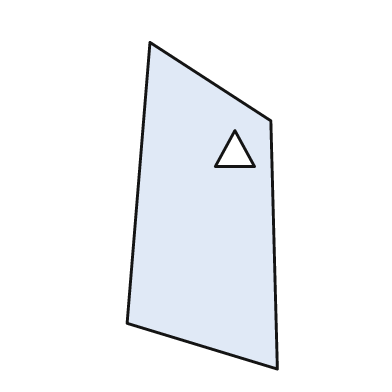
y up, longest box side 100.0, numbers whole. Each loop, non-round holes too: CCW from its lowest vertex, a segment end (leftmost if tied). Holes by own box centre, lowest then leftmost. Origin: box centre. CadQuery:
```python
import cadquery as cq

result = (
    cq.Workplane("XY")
    .moveTo(23.0, -50.0)
    .lineTo(21.0, 26.0)
    .lineTo(-16.0, 50.0)
    .lineTo(-23.0, -36.0)
    .close()
    .moveTo(4.0, 12.0)
    .lineTo(16.0, 12.0)
    .lineTo(10.0, 23.0)
    .close()
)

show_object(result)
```